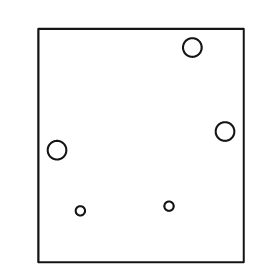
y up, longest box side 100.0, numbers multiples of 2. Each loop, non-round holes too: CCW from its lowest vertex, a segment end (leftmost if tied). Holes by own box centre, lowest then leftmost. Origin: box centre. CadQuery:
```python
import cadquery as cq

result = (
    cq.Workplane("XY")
    .moveTo(-44.0, -50.0)
    .lineTo(44.0, -50.0)
    .lineTo(44.0, 50.0)
    .lineTo(-44.0, 50.0)
    .close()
    .moveTo(-26.0, -28.0)
    .circle(2.0)
    .moveTo(12.0, -26.0)
    .circle(2.0)
    .moveTo(-36.0, -2.0)
    .circle(4.0)
    .moveTo(36.0, 6.0)
    .circle(4.0)
    .moveTo(22.0, 42.0)
    .circle(4.0)
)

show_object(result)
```